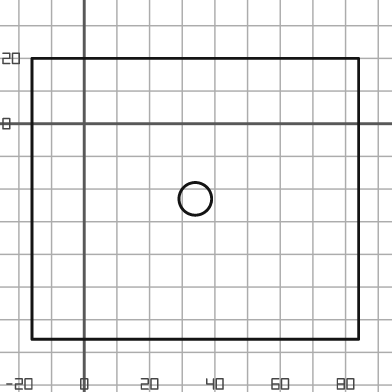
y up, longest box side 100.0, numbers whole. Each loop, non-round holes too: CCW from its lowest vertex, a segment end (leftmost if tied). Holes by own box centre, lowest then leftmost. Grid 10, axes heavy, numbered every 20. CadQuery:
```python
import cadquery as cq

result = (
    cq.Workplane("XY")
    .moveTo(-16.0, -66.0)
    .lineTo(84.0, -66.0)
    .lineTo(84.0, 20.0)
    .lineTo(-16.0, 20.0)
    .close()
    .moveTo(34.0, -23.0)
    .circle(5.0)
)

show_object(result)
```